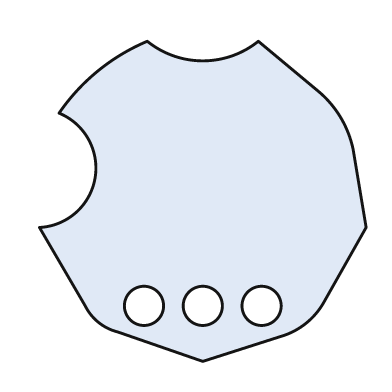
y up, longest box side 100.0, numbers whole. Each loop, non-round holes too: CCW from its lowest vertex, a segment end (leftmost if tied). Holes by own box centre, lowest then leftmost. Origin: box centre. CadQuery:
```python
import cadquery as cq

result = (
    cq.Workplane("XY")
    .moveTo(0.0, -49.0)
    .lineTo(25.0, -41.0)
    .threePointArc((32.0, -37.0), (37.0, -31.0))
    .lineTo(50.0, -8.0)
    .lineTo(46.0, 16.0)
    .threePointArc((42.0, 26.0), (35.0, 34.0))
    .lineTo(17.0, 49.0)
    .threePointArc((0.0, 43.0), (-17.0, 49.0))
    .threePointArc((-32.0, 40.0), (-44.0, 27.0))
    .threePointArc((-33.0, 7.0), (-50.0, -8.0))
    .lineTo(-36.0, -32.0)
    .threePointArc((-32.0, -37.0), (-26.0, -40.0))
    .close()
    .moveTo(-18.0, -32.0)
    .circle(6.0)
    .moveTo(0.0, -32.0)
    .circle(6.0)
    .moveTo(18.0, -32.0)
    .circle(6.0)
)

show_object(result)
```